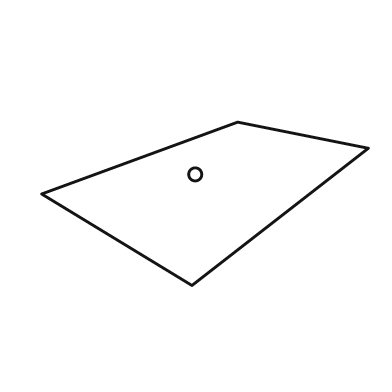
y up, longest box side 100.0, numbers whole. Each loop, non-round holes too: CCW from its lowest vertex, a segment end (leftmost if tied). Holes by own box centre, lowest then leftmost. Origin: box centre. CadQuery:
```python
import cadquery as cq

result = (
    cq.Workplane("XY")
    .moveTo(-4.0, -25.0)
    .lineTo(50.0, 17.0)
    .lineTo(10.0, 25.0)
    .lineTo(-50.0, 3.0)
    .close()
    .moveTo(-3.0, 9.0)
    .circle(2.0)
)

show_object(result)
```